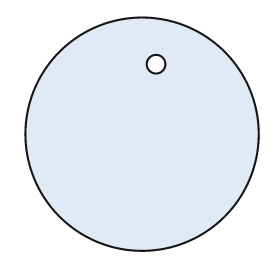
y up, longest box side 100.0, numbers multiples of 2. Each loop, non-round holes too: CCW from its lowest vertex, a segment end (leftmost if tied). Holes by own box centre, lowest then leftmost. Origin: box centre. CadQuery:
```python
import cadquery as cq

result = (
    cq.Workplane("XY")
    .moveTo(0.0, 0.0)
    .circle(50.0)
    .moveTo(6.0, 30.0)
    .circle(4.0)
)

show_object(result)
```